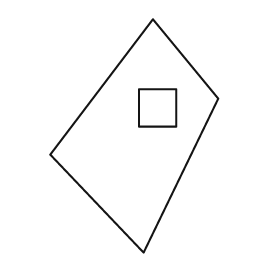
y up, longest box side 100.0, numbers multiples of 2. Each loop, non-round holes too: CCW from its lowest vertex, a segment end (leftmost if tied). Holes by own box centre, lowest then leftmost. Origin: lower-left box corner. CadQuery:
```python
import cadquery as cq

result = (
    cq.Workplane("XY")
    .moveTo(40.0, 0.0)
    .lineTo(72.0, 66.0)
    .lineTo(44.0, 100.0)
    .lineTo(0.0, 42.0)
    .close()
    .moveTo(38.0, 54.0)
    .lineTo(54.0, 54.0)
    .lineTo(54.0, 70.0)
    .lineTo(38.0, 70.0)
    .close()
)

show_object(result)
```